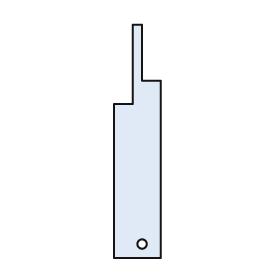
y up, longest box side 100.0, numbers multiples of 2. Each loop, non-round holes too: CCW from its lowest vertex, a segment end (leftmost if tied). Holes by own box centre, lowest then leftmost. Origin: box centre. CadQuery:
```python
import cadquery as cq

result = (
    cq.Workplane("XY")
    .moveTo(-10.0, -50.0)
    .lineTo(10.0, -50.0)
    .lineTo(10.0, 26.0)
    .lineTo(2.0, 26.0)
    .lineTo(2.0, 50.0)
    .lineTo(-2.0, 50.0)
    .lineTo(-2.0, 16.0)
    .lineTo(-10.0, 16.0)
    .close()
    .moveTo(2.0, -44.0)
    .circle(2.0)
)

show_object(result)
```